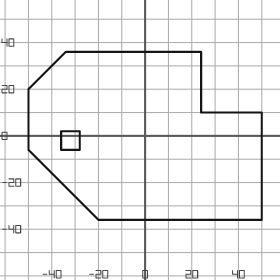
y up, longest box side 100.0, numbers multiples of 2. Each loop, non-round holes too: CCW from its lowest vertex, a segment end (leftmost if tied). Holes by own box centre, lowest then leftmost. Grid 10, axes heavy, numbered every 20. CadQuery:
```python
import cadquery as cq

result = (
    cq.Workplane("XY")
    .moveTo(-20.0, -36.0)
    .lineTo(50.0, -36.0)
    .lineTo(50.0, 10.0)
    .lineTo(24.0, 10.0)
    .lineTo(24.0, 36.0)
    .lineTo(-34.0, 36.0)
    .lineTo(-50.0, 20.0)
    .lineTo(-50.0, -6.0)
    .close()
    .moveTo(-36.0, -6.0)
    .lineTo(-28.0, -6.0)
    .lineTo(-28.0, 2.0)
    .lineTo(-36.0, 2.0)
    .close()
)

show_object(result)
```